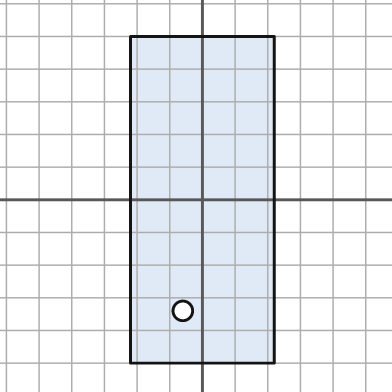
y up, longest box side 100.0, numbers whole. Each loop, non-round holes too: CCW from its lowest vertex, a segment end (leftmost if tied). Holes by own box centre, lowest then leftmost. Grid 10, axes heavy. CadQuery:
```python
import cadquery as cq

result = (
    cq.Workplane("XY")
    .moveTo(-22.0, -50.0)
    .lineTo(22.0, -50.0)
    .lineTo(22.0, 50.0)
    .lineTo(-22.0, 50.0)
    .close()
    .moveTo(-6.0, -34.0)
    .circle(3.0)
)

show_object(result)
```